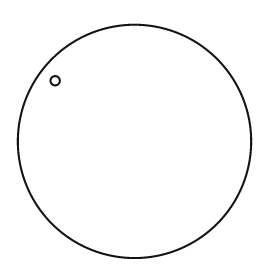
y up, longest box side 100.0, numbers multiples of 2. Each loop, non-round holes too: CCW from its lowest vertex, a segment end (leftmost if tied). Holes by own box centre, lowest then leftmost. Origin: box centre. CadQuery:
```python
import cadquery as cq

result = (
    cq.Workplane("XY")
    .moveTo(0.0, 0.0)
    .circle(50.0)
    .moveTo(-34.0, 26.0)
    .circle(2.0)
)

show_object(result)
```